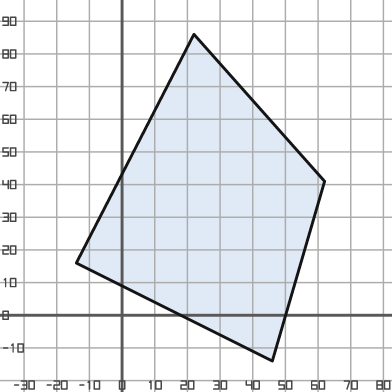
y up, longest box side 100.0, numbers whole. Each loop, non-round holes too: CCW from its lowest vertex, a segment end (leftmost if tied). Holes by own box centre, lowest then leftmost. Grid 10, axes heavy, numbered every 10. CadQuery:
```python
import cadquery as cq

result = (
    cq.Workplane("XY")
    .moveTo(46.0, -14.0)
    .lineTo(62.0, 41.0)
    .lineTo(22.0, 86.0)
    .lineTo(-14.0, 16.0)
    .close()
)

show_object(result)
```